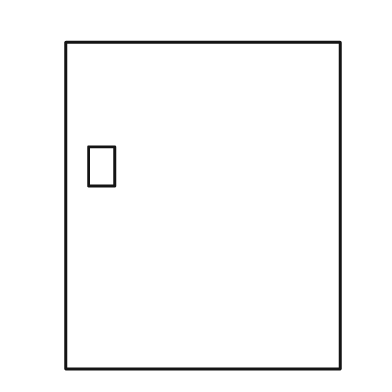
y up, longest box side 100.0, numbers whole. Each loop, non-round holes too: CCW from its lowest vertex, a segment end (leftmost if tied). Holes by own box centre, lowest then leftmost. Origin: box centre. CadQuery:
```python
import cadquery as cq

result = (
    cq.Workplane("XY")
    .moveTo(-42.0, -50.0)
    .lineTo(42.0, -50.0)
    .lineTo(42.0, 50.0)
    .lineTo(-42.0, 50.0)
    .close()
    .moveTo(-35.0, 6.0)
    .lineTo(-27.0, 6.0)
    .lineTo(-27.0, 18.0)
    .lineTo(-35.0, 18.0)
    .close()
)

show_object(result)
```